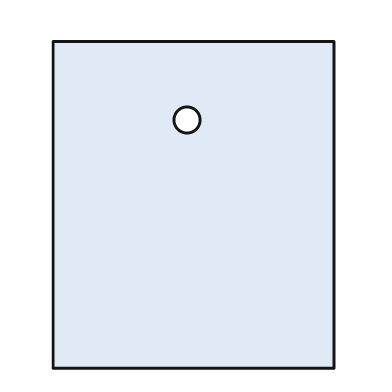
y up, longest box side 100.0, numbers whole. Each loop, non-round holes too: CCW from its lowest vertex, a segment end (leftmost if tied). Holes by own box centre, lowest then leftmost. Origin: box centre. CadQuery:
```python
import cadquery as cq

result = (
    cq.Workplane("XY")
    .moveTo(-43.0, -50.0)
    .lineTo(43.0, -50.0)
    .lineTo(43.0, 50.0)
    .lineTo(-43.0, 50.0)
    .close()
    .moveTo(-2.0, 26.0)
    .circle(4.0)
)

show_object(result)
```